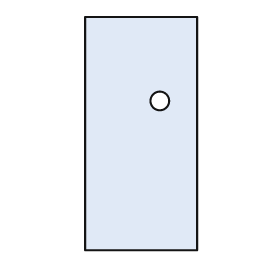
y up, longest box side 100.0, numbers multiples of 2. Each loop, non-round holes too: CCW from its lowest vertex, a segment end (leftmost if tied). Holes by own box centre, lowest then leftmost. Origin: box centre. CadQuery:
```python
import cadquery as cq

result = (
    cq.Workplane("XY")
    .moveTo(-24.0, -50.0)
    .lineTo(24.0, -50.0)
    .lineTo(24.0, 50.0)
    .lineTo(-24.0, 50.0)
    .close()
    .moveTo(8.0, 14.0)
    .circle(4.0)
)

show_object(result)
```